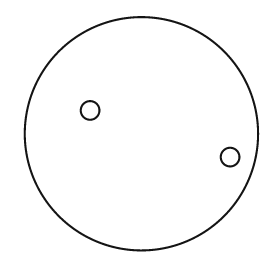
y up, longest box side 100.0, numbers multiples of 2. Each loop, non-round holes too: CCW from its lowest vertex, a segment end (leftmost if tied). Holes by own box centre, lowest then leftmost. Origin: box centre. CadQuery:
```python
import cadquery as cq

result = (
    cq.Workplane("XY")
    .moveTo(0.0, 0.0)
    .circle(50.0)
    .moveTo(38.0, -10.0)
    .circle(4.0)
    .moveTo(-22.0, 10.0)
    .circle(4.0)
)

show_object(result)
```